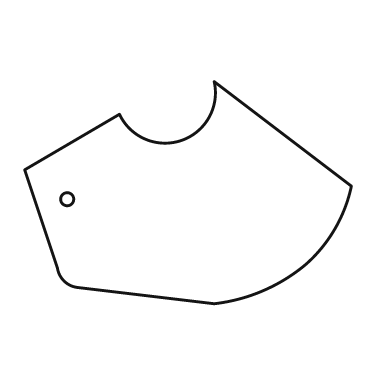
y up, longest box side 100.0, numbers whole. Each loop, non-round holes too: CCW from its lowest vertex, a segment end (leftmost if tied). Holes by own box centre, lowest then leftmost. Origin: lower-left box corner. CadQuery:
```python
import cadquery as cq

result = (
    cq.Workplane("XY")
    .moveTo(58.0, 0.0)
    .threePointArc((73.0, 4.0), (86.0, 12.0))
    .threePointArc((95.0, 23.0), (100.0, 36.0))
    .lineTo(58.0, 68.0)
    .threePointArc((48.0, 50.0), (29.0, 58.0))
    .lineTo(0.0, 41.0)
    .lineTo(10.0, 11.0)
    .threePointArc((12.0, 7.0), (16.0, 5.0))
    .close()
    .moveTo(13.0, 32.0)
    .circle(2.0)
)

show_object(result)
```